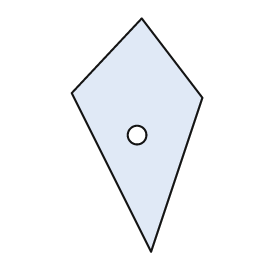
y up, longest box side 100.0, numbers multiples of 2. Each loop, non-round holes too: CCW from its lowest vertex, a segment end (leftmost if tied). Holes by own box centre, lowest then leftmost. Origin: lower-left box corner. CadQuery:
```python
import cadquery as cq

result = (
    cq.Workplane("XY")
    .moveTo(34.0, 0.0)
    .lineTo(56.0, 66.0)
    .lineTo(30.0, 100.0)
    .lineTo(0.0, 68.0)
    .close()
    .moveTo(28.0, 50.0)
    .circle(4.0)
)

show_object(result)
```